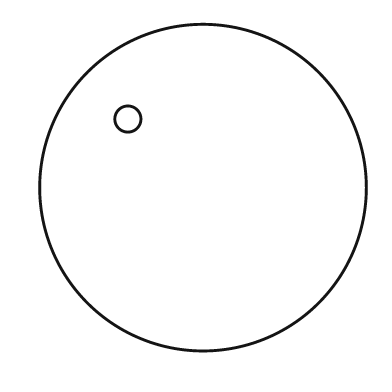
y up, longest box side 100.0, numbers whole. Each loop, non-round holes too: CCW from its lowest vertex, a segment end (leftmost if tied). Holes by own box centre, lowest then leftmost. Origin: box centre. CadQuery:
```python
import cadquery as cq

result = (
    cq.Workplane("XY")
    .moveTo(0.0, 0.0)
    .circle(50.0)
    .moveTo(-23.0, 21.0)
    .circle(4.0)
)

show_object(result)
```